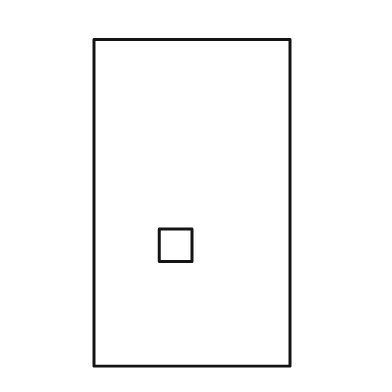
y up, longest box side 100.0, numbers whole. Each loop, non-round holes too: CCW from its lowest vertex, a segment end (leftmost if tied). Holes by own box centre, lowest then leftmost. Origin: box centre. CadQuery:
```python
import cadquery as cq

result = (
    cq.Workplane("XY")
    .moveTo(-30.0, -50.0)
    .lineTo(30.0, -50.0)
    .lineTo(30.0, 50.0)
    .lineTo(-30.0, 50.0)
    .close()
    .moveTo(-10.0, -18.0)
    .lineTo(0.0, -18.0)
    .lineTo(0.0, -8.0)
    .lineTo(-10.0, -8.0)
    .close()
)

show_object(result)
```